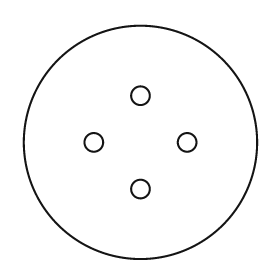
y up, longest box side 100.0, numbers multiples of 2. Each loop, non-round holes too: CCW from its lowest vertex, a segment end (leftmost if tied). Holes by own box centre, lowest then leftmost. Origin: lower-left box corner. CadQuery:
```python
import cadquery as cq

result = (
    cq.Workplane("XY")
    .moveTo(50.0, 50.0)
    .circle(50.0)
    .moveTo(50.0, 30.0)
    .circle(4.0)
    .moveTo(30.0, 50.0)
    .circle(4.0)
    .moveTo(70.0, 50.0)
    .circle(4.0)
    .moveTo(50.0, 70.0)
    .circle(4.0)
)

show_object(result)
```